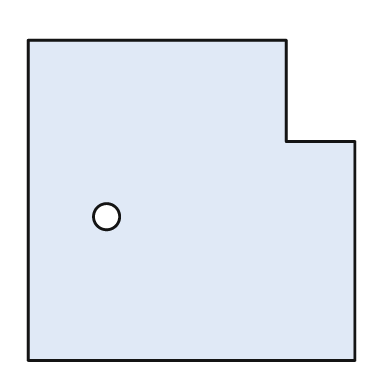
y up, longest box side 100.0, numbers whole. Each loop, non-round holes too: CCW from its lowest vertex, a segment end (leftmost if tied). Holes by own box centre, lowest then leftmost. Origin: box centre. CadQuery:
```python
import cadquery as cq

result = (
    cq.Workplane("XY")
    .moveTo(-50.0, -49.0)
    .lineTo(50.0, -49.0)
    .lineTo(50.0, 18.0)
    .lineTo(29.0, 18.0)
    .lineTo(29.0, 49.0)
    .lineTo(-50.0, 49.0)
    .close()
    .moveTo(-26.0, -5.0)
    .circle(4.0)
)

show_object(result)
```